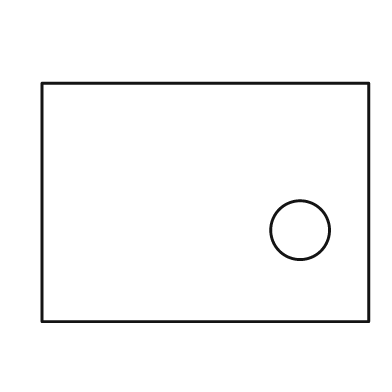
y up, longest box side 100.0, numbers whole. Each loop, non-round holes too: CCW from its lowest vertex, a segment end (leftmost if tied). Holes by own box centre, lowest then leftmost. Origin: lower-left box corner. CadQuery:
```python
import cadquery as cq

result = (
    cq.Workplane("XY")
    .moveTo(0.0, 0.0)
    .lineTo(100.0, 0.0)
    .lineTo(100.0, 73.0)
    .lineTo(0.0, 73.0)
    .close()
    .moveTo(79.0, 28.0)
    .circle(9.0)
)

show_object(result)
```